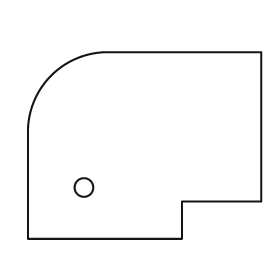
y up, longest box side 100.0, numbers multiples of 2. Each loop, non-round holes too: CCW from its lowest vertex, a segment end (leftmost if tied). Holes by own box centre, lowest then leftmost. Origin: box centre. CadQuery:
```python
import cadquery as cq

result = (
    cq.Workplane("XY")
    .moveTo(-50.0, -40.0)
    .lineTo(16.0, -40.0)
    .lineTo(16.0, -24.0)
    .lineTo(50.0, -24.0)
    .lineTo(50.0, 40.0)
    .lineTo(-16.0, 40.0)
    .threePointArc((-40.0, 30.0), (-50.0, 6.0))
    .close()
    .moveTo(-26.0, -18.0)
    .circle(4.0)
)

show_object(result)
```